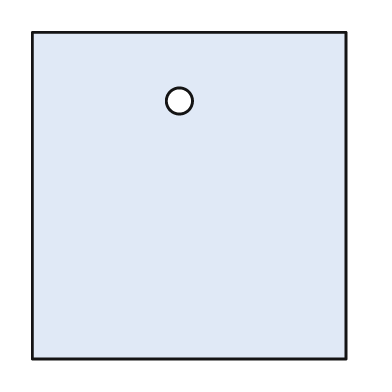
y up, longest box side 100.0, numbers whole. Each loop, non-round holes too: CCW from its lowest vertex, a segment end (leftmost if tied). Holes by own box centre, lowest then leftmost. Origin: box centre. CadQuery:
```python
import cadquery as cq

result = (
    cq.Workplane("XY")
    .moveTo(-48.0, -50.0)
    .lineTo(48.0, -50.0)
    .lineTo(48.0, 50.0)
    .lineTo(-48.0, 50.0)
    .close()
    .moveTo(-3.0, 29.0)
    .circle(4.0)
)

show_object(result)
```